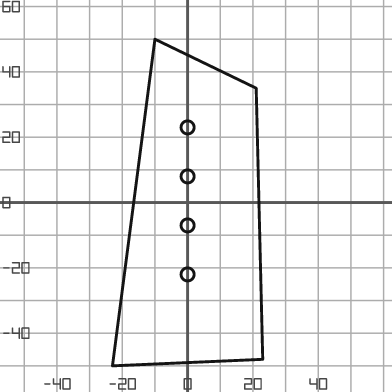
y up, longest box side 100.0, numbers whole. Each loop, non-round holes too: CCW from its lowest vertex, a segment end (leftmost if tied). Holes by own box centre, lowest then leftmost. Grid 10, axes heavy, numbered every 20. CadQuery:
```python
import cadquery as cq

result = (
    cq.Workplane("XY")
    .moveTo(-23.0, -50.0)
    .lineTo(23.0, -48.0)
    .lineTo(21.0, 35.0)
    .lineTo(-10.0, 50.0)
    .close()
    .moveTo(0.0, -22.0)
    .circle(2.0)
    .moveTo(0.0, -7.0)
    .circle(2.0)
    .moveTo(0.0, 8.0)
    .circle(2.0)
    .moveTo(0.0, 23.0)
    .circle(2.0)
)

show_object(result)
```